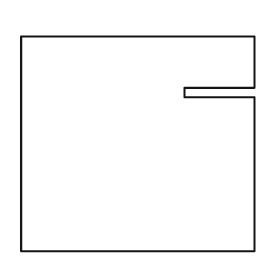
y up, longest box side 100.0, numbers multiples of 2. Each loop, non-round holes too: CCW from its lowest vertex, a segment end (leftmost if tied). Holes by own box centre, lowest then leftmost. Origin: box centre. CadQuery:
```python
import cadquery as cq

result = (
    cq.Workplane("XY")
    .moveTo(-50.0, -46.0)
    .lineTo(50.0, -46.0)
    .lineTo(50.0, 20.0)
    .lineTo(20.0, 20.0)
    .lineTo(20.0, 24.0)
    .lineTo(50.0, 24.0)
    .lineTo(50.0, 46.0)
    .lineTo(-50.0, 46.0)
    .close()
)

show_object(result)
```